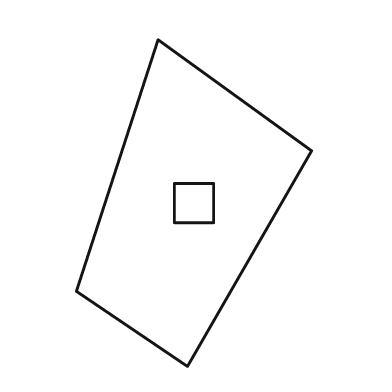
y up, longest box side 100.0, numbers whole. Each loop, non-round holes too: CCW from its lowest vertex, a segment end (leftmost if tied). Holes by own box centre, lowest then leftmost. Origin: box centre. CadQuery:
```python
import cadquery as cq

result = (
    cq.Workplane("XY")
    .moveTo(-2.0, -50.0)
    .lineTo(36.0, 16.0)
    .lineTo(-11.0, 50.0)
    .lineTo(-36.0, -27.0)
    .close()
    .moveTo(-6.0, -6.0)
    .lineTo(6.0, -6.0)
    .lineTo(6.0, 6.0)
    .lineTo(-6.0, 6.0)
    .close()
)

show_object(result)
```